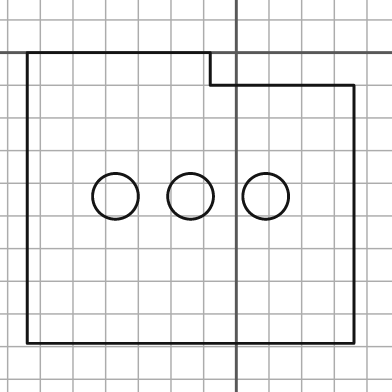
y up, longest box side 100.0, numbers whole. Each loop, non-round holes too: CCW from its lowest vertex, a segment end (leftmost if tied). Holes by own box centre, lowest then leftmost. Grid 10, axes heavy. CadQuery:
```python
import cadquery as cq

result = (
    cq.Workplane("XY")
    .moveTo(-64.0, -89.0)
    .lineTo(36.0, -89.0)
    .lineTo(36.0, -10.0)
    .lineTo(-8.0, -10.0)
    .lineTo(-8.0, 0.0)
    .lineTo(-64.0, 0.0)
    .close()
    .moveTo(-37.0, -44.0)
    .circle(7.0)
    .moveTo(-14.0, -44.0)
    .circle(7.0)
    .moveTo(9.0, -44.0)
    .circle(7.0)
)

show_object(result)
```